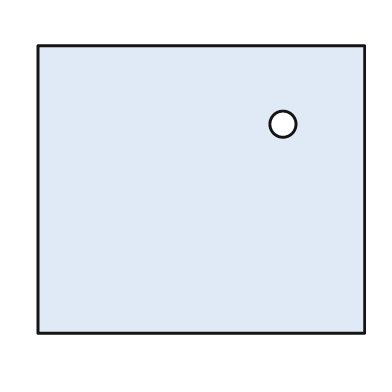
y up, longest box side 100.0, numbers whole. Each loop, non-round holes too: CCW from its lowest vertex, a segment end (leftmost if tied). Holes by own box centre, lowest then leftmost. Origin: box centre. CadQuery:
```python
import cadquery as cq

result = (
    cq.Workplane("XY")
    .moveTo(-50.0, -44.0)
    .lineTo(50.0, -44.0)
    .lineTo(50.0, 44.0)
    .lineTo(-50.0, 44.0)
    .close()
    .moveTo(25.0, 20.0)
    .circle(4.0)
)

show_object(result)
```